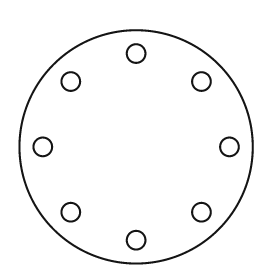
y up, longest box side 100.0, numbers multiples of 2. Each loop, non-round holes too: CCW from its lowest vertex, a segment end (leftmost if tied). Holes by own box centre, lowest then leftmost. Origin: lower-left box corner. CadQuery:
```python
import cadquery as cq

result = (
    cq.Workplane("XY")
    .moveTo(50.0, 50.0)
    .circle(50.0)
    .moveTo(50.0, 10.0)
    .circle(4.0)
    .moveTo(22.0, 22.0)
    .circle(4.0)
    .moveTo(78.0, 22.0)
    .circle(4.0)
    .moveTo(10.0, 50.0)
    .circle(4.0)
    .moveTo(90.0, 50.0)
    .circle(4.0)
    .moveTo(22.0, 78.0)
    .circle(4.0)
    .moveTo(78.0, 78.0)
    .circle(4.0)
    .moveTo(50.0, 90.0)
    .circle(4.0)
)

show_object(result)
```